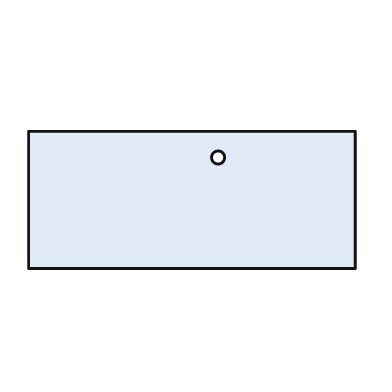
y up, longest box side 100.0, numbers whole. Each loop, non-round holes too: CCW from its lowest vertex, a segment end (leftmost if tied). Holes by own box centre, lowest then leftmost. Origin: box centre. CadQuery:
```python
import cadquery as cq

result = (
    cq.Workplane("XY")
    .moveTo(-50.0, -21.0)
    .lineTo(50.0, -21.0)
    .lineTo(50.0, 21.0)
    .lineTo(-50.0, 21.0)
    .close()
    .moveTo(8.0, 13.0)
    .circle(2.0)
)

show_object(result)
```